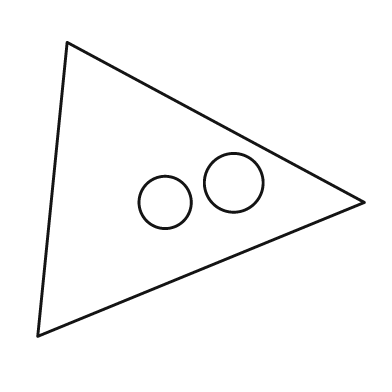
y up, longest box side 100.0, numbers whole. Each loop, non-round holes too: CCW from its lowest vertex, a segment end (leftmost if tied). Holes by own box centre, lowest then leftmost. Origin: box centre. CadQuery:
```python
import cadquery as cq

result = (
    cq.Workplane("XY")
    .moveTo(-50.0, -45.0)
    .lineTo(50.0, -4.0)
    .lineTo(-41.0, 45.0)
    .close()
    .moveTo(-11.0, -4.0)
    .circle(8.0)
    .moveTo(10.0, 2.0)
    .circle(9.0)
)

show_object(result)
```